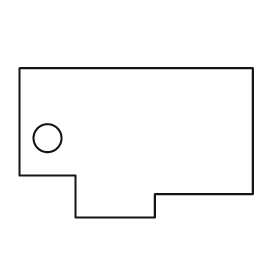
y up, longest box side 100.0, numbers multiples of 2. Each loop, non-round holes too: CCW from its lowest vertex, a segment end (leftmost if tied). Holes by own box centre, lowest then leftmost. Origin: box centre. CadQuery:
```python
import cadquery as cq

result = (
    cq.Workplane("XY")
    .moveTo(-26.0, -32.0)
    .lineTo(8.0, -32.0)
    .lineTo(8.0, -22.0)
    .lineTo(50.0, -22.0)
    .lineTo(50.0, 32.0)
    .lineTo(-50.0, 32.0)
    .lineTo(-50.0, -14.0)
    .lineTo(-26.0, -14.0)
    .close()
    .moveTo(-38.0, 2.0)
    .circle(6.0)
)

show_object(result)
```